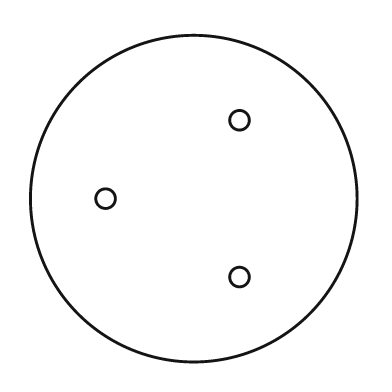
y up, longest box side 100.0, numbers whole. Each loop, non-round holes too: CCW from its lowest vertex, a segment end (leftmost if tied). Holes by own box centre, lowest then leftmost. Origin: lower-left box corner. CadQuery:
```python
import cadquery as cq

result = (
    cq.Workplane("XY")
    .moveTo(50.0, 50.0)
    .circle(50.0)
    .moveTo(64.0, 26.0)
    .circle(3.0)
    .moveTo(23.0, 50.0)
    .circle(3.0)
    .moveTo(64.0, 74.0)
    .circle(3.0)
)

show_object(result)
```